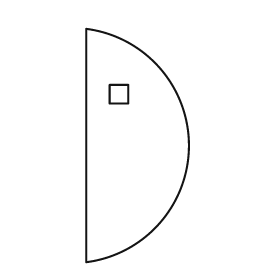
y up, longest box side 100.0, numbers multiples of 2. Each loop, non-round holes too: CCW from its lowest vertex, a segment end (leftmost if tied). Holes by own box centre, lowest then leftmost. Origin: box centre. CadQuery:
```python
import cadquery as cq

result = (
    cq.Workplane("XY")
    .moveTo(-22.0, -50.0)
    .threePointArc((22.0, 0.0), (-22.0, 50.0))
    .close()
    .moveTo(-12.0, 18.0)
    .lineTo(-4.0, 18.0)
    .lineTo(-4.0, 26.0)
    .lineTo(-12.0, 26.0)
    .close()
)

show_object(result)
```